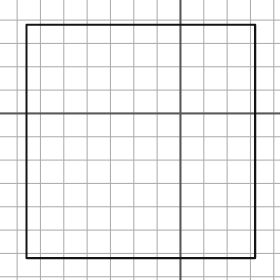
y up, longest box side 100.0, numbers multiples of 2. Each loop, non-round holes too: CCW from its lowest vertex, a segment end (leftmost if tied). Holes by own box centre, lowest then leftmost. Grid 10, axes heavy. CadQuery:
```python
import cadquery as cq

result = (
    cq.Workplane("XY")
    .moveTo(-66.0, -62.0)
    .lineTo(32.0, -62.0)
    .lineTo(32.0, 38.0)
    .lineTo(-66.0, 38.0)
    .close()
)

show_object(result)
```